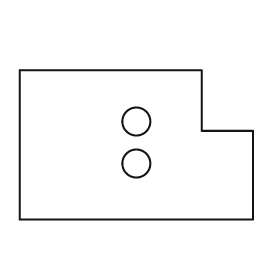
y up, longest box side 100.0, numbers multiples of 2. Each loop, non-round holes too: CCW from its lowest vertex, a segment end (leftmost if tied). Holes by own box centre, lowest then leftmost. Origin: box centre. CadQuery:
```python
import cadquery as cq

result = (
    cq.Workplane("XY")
    .moveTo(-50.0, -32.0)
    .lineTo(50.0, -32.0)
    .lineTo(50.0, 6.0)
    .lineTo(28.0, 6.0)
    .lineTo(28.0, 32.0)
    .lineTo(-50.0, 32.0)
    .close()
    .moveTo(0.0, -8.0)
    .circle(6.0)
    .moveTo(0.0, 10.0)
    .circle(6.0)
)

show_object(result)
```